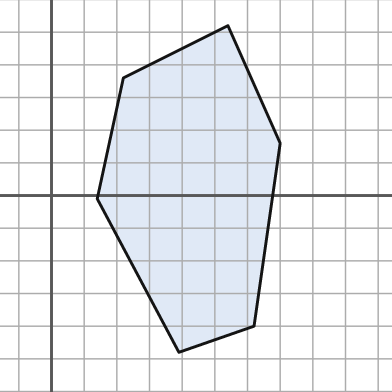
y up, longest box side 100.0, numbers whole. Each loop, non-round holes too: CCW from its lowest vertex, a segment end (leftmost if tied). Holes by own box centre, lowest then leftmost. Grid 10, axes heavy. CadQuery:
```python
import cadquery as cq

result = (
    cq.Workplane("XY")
    .moveTo(39.0, -48.0)
    .lineTo(62.0, -40.0)
    .lineTo(70.0, 16.0)
    .lineTo(54.0, 52.0)
    .lineTo(22.0, 36.0)
    .lineTo(14.0, -1.0)
    .close()
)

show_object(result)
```